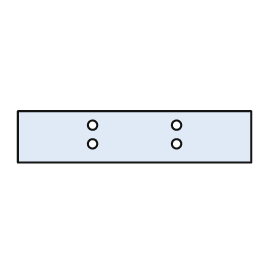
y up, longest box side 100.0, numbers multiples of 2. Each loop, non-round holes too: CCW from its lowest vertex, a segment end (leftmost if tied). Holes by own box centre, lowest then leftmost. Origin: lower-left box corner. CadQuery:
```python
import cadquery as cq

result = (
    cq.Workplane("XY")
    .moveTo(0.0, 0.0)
    .lineTo(100.0, 0.0)
    .lineTo(100.0, 22.0)
    .lineTo(0.0, 22.0)
    .close()
    .moveTo(32.0, 8.0)
    .circle(2.0)
    .moveTo(68.0, 8.0)
    .circle(2.0)
    .moveTo(32.0, 16.0)
    .circle(2.0)
    .moveTo(68.0, 16.0)
    .circle(2.0)
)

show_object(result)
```